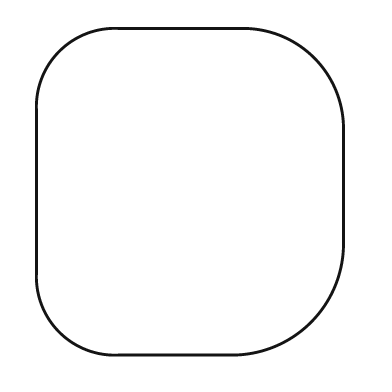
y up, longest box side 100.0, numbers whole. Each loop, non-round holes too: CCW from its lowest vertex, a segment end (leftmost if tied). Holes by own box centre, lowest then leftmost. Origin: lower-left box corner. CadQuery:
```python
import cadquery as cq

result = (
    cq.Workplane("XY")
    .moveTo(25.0, 0.0)
    .lineTo(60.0, 0.0)
    .threePointArc((84.0, 10.0), (94.0, 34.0))
    .lineTo(94.0, 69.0)
    .threePointArc((85.0, 91.0), (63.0, 100.0))
    .lineTo(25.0, 100.0)
    .threePointArc((7.0, 93.0), (0.0, 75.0))
    .lineTo(0.0, 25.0)
    .threePointArc((7.0, 7.0), (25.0, 0.0))
    .close()
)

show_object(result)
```